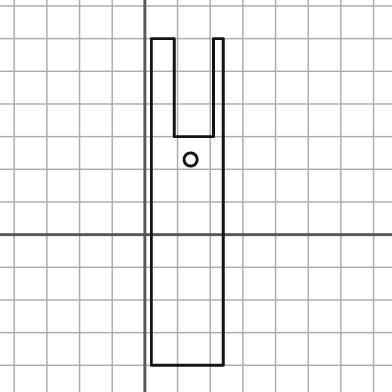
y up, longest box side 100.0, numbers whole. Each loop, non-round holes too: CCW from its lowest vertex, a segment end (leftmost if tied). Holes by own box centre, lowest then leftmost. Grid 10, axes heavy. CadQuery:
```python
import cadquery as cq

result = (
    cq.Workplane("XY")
    .moveTo(2.0, -40.0)
    .lineTo(24.0, -40.0)
    .lineTo(24.0, 60.0)
    .lineTo(21.0, 60.0)
    .lineTo(21.0, 30.0)
    .lineTo(9.0, 30.0)
    .lineTo(9.0, 60.0)
    .lineTo(2.0, 60.0)
    .close()
    .moveTo(14.0, 23.0)
    .circle(2.0)
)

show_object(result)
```